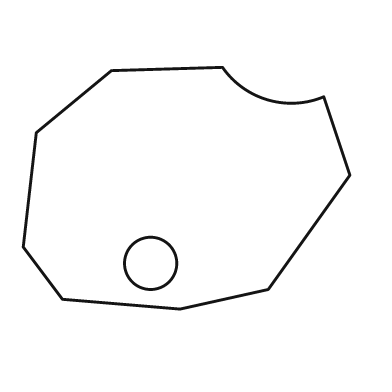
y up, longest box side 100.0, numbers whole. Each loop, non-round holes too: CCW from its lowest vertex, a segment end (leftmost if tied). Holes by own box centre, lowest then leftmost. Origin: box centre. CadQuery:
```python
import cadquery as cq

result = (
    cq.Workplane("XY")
    .moveTo(-2.0, -37.0)
    .lineTo(25.0, -31.0)
    .lineTo(50.0, 4.0)
    .lineTo(42.0, 28.0)
    .threePointArc((25.0, 27.0), (11.0, 37.0))
    .lineTo(-23.0, 36.0)
    .lineTo(-46.0, 17.0)
    .lineTo(-50.0, -18.0)
    .lineTo(-38.0, -34.0)
    .close()
    .moveTo(-11.0, -23.0)
    .circle(8.0)
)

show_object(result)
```